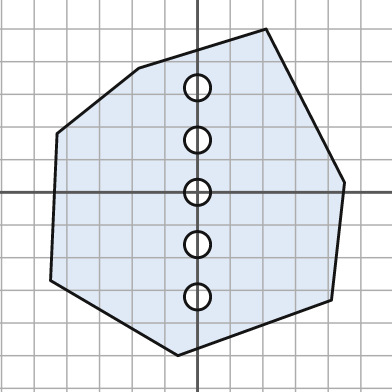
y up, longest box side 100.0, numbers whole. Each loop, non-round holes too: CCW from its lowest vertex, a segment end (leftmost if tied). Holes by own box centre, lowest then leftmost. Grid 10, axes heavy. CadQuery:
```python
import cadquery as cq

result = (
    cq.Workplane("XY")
    .moveTo(-6.0, -50.0)
    .lineTo(41.0, -33.0)
    .lineTo(45.0, 3.0)
    .lineTo(21.0, 50.0)
    .lineTo(-18.0, 38.0)
    .lineTo(-43.0, 18.0)
    .lineTo(-45.0, -27.0)
    .close()
    .moveTo(0.0, -32.0)
    .circle(4.0)
    .moveTo(0.0, -16.0)
    .circle(4.0)
    .moveTo(0.0, 0.0)
    .circle(4.0)
    .moveTo(0.0, 16.0)
    .circle(4.0)
    .moveTo(0.0, 32.0)
    .circle(4.0)
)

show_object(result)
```